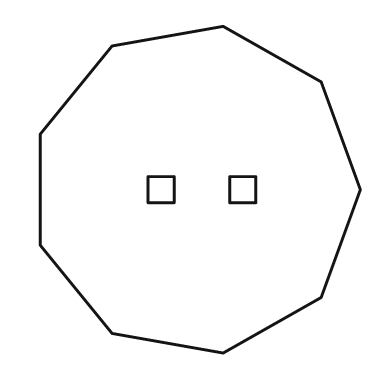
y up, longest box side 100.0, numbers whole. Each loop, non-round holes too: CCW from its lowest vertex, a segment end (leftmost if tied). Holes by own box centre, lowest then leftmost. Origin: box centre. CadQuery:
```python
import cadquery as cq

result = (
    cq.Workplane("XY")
    .moveTo(7.0, -50.0)
    .lineTo(37.0, -33.0)
    .lineTo(49.0, 0.0)
    .lineTo(37.0, 33.0)
    .lineTo(7.0, 50.0)
    .lineTo(-27.0, 44.0)
    .lineTo(-49.0, 17.0)
    .lineTo(-49.0, -17.0)
    .lineTo(-27.0, -44.0)
    .close()
    .moveTo(-16.0, -4.0)
    .lineTo(-8.0, -4.0)
    .lineTo(-8.0, 4.0)
    .lineTo(-16.0, 4.0)
    .close()
    .moveTo(9.0, -4.0)
    .lineTo(17.0, -4.0)
    .lineTo(17.0, 4.0)
    .lineTo(9.0, 4.0)
    .close()
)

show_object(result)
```